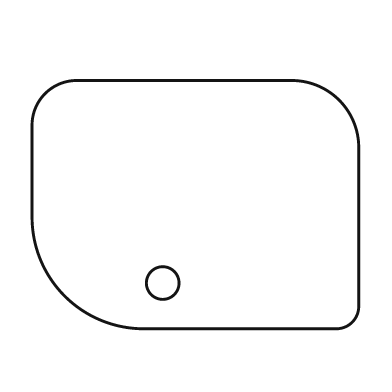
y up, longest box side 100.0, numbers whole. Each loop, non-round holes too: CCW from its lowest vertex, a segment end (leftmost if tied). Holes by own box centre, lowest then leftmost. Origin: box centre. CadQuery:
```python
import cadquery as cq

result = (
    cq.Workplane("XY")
    .moveTo(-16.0, -38.0)
    .lineTo(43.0, -38.0)
    .threePointArc((48.0, -36.0), (50.0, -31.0))
    .lineTo(50.0, 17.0)
    .threePointArc((44.0, 32.0), (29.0, 38.0))
    .lineTo(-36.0, 38.0)
    .threePointArc((-46.0, 34.0), (-50.0, 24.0))
    .lineTo(-50.0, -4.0)
    .threePointArc((-40.0, -28.0), (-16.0, -38.0))
    .close()
    .moveTo(-10.0, -24.0)
    .circle(5.0)
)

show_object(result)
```